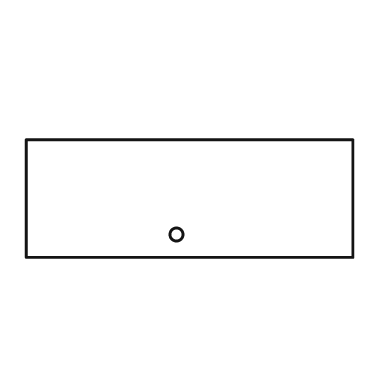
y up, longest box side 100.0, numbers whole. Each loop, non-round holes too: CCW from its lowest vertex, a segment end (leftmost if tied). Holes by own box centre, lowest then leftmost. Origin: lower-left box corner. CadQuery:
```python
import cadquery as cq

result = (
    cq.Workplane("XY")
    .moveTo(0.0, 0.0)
    .lineTo(100.0, 0.0)
    .lineTo(100.0, 36.0)
    .lineTo(0.0, 36.0)
    .close()
    .moveTo(46.0, 7.0)
    .circle(2.0)
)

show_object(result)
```